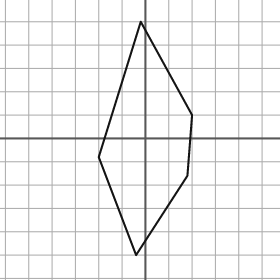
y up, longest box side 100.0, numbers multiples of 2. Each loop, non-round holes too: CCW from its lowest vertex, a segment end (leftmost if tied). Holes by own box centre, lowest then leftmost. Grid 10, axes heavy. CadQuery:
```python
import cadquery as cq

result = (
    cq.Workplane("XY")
    .moveTo(-4.0, -50.0)
    .lineTo(18.0, -16.0)
    .lineTo(20.0, 10.0)
    .lineTo(-2.0, 50.0)
    .lineTo(-20.0, -8.0)
    .close()
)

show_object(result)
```